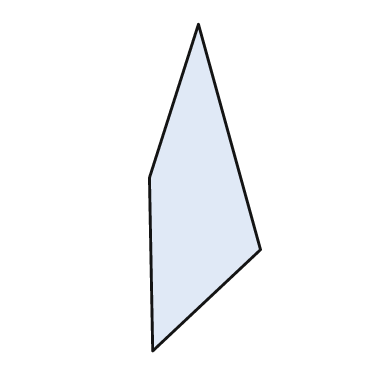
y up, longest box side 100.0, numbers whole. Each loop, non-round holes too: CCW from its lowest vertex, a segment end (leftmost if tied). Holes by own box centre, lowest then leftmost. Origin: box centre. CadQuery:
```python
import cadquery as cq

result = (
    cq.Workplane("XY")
    .moveTo(-16.0, -50.0)
    .lineTo(17.0, -19.0)
    .lineTo(-2.0, 50.0)
    .lineTo(-17.0, 3.0)
    .close()
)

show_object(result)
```